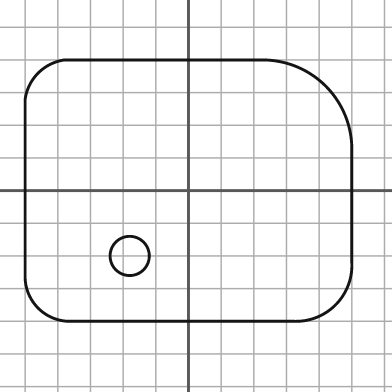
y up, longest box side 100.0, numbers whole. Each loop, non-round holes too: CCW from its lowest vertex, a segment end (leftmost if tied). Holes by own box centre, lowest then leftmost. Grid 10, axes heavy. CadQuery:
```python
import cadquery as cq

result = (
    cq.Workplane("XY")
    .moveTo(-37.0, -40.0)
    .lineTo(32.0, -40.0)
    .threePointArc((45.0, -35.0), (50.0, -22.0))
    .lineTo(50.0, 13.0)
    .threePointArc((42.0, 32.0), (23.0, 40.0))
    .lineTo(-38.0, 40.0)
    .threePointArc((-46.0, 36.0), (-50.0, 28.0))
    .lineTo(-50.0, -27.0)
    .threePointArc((-46.0, -36.0), (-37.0, -40.0))
    .close()
    .moveTo(-18.0, -20.0)
    .circle(6.0)
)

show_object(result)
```